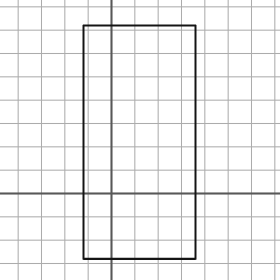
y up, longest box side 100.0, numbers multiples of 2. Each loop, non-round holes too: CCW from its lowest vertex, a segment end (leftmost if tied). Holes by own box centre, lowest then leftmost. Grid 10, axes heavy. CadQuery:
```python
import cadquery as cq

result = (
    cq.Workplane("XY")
    .moveTo(-12.0, -28.0)
    .lineTo(36.0, -28.0)
    .lineTo(36.0, 72.0)
    .lineTo(-12.0, 72.0)
    .close()
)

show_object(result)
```